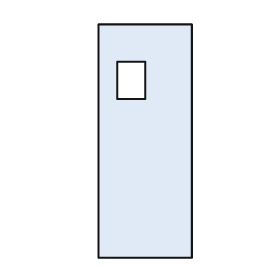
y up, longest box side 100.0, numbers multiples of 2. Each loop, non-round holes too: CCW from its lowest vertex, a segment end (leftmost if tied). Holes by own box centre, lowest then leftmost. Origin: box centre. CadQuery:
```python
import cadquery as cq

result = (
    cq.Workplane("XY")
    .moveTo(-20.0, -50.0)
    .lineTo(20.0, -50.0)
    .lineTo(20.0, 50.0)
    .lineTo(-20.0, 50.0)
    .close()
    .moveTo(-12.0, 18.0)
    .lineTo(0.0, 18.0)
    .lineTo(0.0, 34.0)
    .lineTo(-12.0, 34.0)
    .close()
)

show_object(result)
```